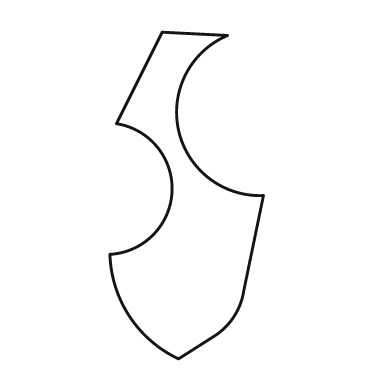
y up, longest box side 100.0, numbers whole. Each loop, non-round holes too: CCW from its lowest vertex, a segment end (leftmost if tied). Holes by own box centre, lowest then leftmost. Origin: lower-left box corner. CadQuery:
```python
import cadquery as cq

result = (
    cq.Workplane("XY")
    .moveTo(21.0, 0.0)
    .lineTo(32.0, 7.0)
    .threePointArc((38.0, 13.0), (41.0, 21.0))
    .lineTo(47.0, 50.0)
    .threePointArc((21.0, 70.0), (36.0, 99.0))
    .lineTo(16.0, 100.0)
    .lineTo(2.0, 72.0)
    .threePointArc((19.0, 51.0), (0.0, 32.0))
    .threePointArc((6.0, 13.0), (21.0, 0.0))
    .close()
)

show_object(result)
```